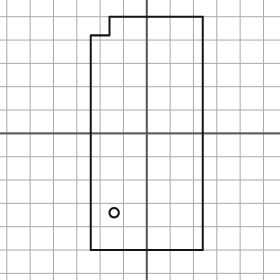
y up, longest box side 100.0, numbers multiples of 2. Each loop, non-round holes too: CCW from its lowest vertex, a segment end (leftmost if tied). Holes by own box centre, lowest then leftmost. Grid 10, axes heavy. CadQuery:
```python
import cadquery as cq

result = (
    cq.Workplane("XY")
    .moveTo(-24.0, -50.0)
    .lineTo(24.0, -50.0)
    .lineTo(24.0, 50.0)
    .lineTo(-16.0, 50.0)
    .lineTo(-16.0, 42.0)
    .lineTo(-24.0, 42.0)
    .close()
    .moveTo(-14.0, -34.0)
    .circle(2.0)
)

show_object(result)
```